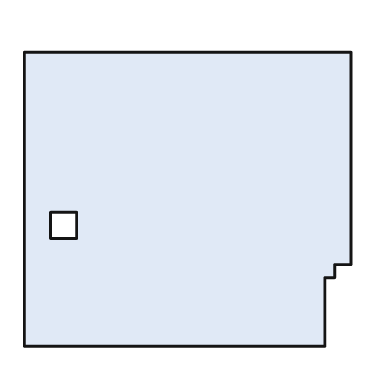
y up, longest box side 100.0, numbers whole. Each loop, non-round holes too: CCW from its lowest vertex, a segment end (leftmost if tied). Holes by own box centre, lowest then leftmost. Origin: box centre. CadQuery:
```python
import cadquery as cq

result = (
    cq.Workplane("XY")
    .moveTo(-50.0, -45.0)
    .lineTo(42.0, -45.0)
    .lineTo(42.0, -24.0)
    .lineTo(45.0, -24.0)
    .lineTo(45.0, -20.0)
    .lineTo(50.0, -20.0)
    .lineTo(50.0, 45.0)
    .lineTo(-50.0, 45.0)
    .close()
    .moveTo(-42.0, -12.0)
    .lineTo(-34.0, -12.0)
    .lineTo(-34.0, -4.0)
    .lineTo(-42.0, -4.0)
    .close()
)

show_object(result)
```